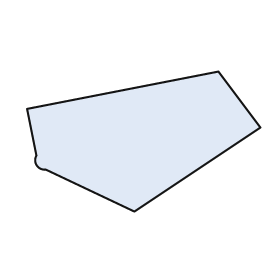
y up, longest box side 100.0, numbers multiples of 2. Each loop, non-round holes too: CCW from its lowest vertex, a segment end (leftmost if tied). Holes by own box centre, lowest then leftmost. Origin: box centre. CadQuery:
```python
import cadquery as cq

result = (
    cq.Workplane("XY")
    .moveTo(-4.0, -30.0)
    .lineTo(50.0, 6.0)
    .lineTo(32.0, 30.0)
    .lineTo(-50.0, 14.0)
    .lineTo(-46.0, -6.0)
    .threePointArc((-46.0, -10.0), (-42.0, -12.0))
    .close()
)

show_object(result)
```